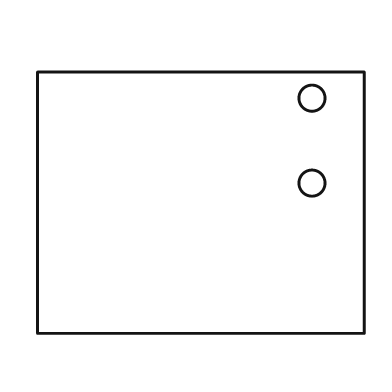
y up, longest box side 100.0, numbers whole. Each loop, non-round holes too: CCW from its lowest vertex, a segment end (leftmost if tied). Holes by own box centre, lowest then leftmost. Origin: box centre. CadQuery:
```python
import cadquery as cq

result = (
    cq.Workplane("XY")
    .moveTo(-50.0, -40.0)
    .lineTo(50.0, -40.0)
    .lineTo(50.0, 40.0)
    .lineTo(-50.0, 40.0)
    .close()
    .moveTo(34.0, 6.0)
    .circle(4.0)
    .moveTo(34.0, 32.0)
    .circle(4.0)
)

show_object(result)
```